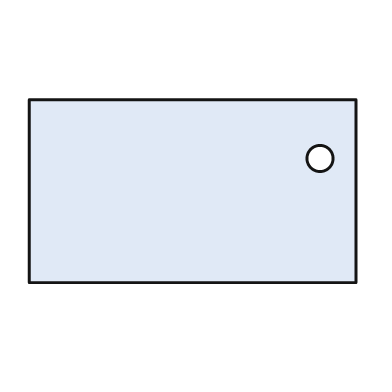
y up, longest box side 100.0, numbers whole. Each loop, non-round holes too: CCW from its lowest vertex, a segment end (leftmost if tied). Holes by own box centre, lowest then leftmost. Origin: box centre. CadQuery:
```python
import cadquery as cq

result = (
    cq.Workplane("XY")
    .moveTo(-50.0, -28.0)
    .lineTo(50.0, -28.0)
    .lineTo(50.0, 28.0)
    .lineTo(-50.0, 28.0)
    .close()
    .moveTo(39.0, 10.0)
    .circle(4.0)
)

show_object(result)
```